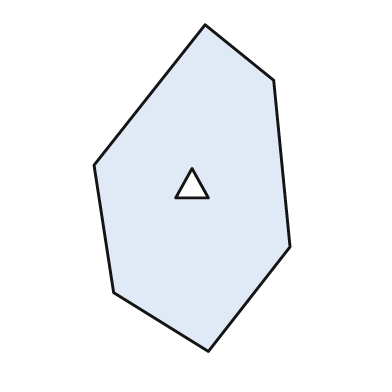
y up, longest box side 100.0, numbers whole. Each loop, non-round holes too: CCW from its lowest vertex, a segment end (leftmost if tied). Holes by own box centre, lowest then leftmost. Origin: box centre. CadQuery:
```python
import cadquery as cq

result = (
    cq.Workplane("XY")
    .moveTo(5.0, -50.0)
    .lineTo(30.0, -18.0)
    .lineTo(25.0, 33.0)
    .lineTo(4.0, 50.0)
    .lineTo(-30.0, 7.0)
    .lineTo(-24.0, -32.0)
    .close()
    .moveTo(-5.0, -3.0)
    .lineTo(5.0, -3.0)
    .lineTo(0.0, 6.0)
    .close()
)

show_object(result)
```